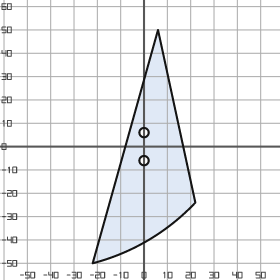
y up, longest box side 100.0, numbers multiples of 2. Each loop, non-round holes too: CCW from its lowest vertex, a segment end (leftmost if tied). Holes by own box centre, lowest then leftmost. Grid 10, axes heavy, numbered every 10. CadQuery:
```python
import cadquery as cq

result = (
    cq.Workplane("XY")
    .moveTo(-22.0, -50.0)
    .threePointArc((2.0, -40.0), (22.0, -24.0))
    .lineTo(6.0, 50.0)
    .close()
    .moveTo(0.0, -6.0)
    .circle(2.0)
    .moveTo(0.0, 6.0)
    .circle(2.0)
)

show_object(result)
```